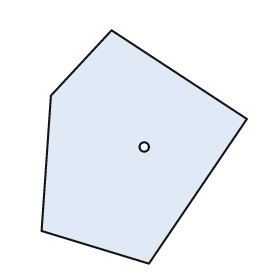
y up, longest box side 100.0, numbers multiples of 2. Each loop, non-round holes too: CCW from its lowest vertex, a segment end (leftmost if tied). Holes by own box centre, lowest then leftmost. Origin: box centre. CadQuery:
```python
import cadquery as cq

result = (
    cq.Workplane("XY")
    .moveTo(2.0, -50.0)
    .lineTo(44.0, 12.0)
    .lineTo(-14.0, 50.0)
    .lineTo(-40.0, 22.0)
    .lineTo(-44.0, -36.0)
    .close()
    .moveTo(0.0, 0.0)
    .circle(2.0)
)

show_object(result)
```